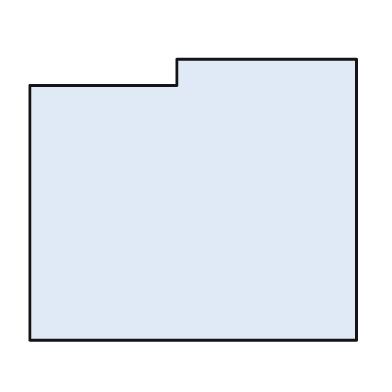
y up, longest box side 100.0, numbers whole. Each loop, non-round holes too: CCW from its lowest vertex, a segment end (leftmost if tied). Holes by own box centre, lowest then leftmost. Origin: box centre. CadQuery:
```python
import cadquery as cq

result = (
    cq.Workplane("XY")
    .moveTo(-50.0, -43.0)
    .lineTo(50.0, -43.0)
    .lineTo(50.0, 43.0)
    .lineTo(-5.0, 43.0)
    .lineTo(-5.0, 35.0)
    .lineTo(-50.0, 35.0)
    .close()
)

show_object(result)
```